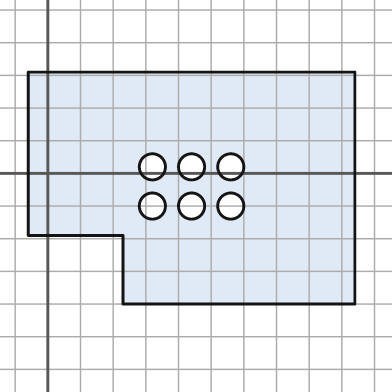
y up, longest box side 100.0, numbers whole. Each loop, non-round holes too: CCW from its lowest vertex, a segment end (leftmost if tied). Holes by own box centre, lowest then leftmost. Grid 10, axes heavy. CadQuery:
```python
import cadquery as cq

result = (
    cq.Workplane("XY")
    .moveTo(23.0, -40.0)
    .lineTo(94.0, -40.0)
    .lineTo(94.0, 31.0)
    .lineTo(-6.0, 31.0)
    .lineTo(-6.0, -19.0)
    .lineTo(23.0, -19.0)
    .close()
    .moveTo(32.0, -10.0)
    .circle(4.0)
    .moveTo(44.0, -10.0)
    .circle(4.0)
    .moveTo(56.0, -10.0)
    .circle(4.0)
    .moveTo(32.0, 2.0)
    .circle(4.0)
    .moveTo(44.0, 2.0)
    .circle(4.0)
    .moveTo(56.0, 2.0)
    .circle(4.0)
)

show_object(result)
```